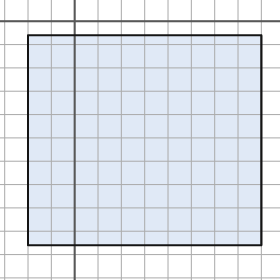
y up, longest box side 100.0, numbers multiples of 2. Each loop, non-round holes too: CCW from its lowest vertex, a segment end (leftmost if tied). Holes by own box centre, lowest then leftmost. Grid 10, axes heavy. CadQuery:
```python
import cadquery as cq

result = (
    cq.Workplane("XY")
    .moveTo(-20.0, -96.0)
    .lineTo(80.0, -96.0)
    .lineTo(80.0, -6.0)
    .lineTo(-20.0, -6.0)
    .close()
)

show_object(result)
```